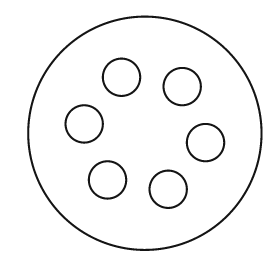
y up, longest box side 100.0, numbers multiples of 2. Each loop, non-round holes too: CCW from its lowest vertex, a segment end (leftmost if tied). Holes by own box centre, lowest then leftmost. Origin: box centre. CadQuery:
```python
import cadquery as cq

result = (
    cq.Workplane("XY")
    .moveTo(0.0, 0.0)
    .circle(50.0)
    .moveTo(10.0, -24.0)
    .circle(8.0)
    .moveTo(-16.0, -20.0)
    .circle(8.0)
    .moveTo(26.0, -4.0)
    .circle(8.0)
    .moveTo(-26.0, 4.0)
    .circle(8.0)
    .moveTo(16.0, 20.0)
    .circle(8.0)
    .moveTo(-10.0, 24.0)
    .circle(8.0)
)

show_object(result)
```